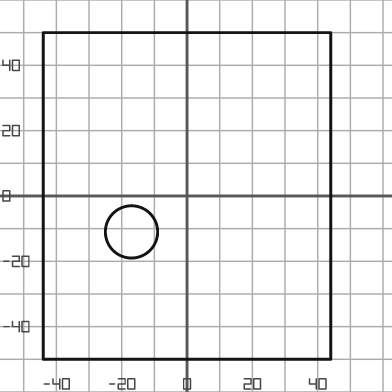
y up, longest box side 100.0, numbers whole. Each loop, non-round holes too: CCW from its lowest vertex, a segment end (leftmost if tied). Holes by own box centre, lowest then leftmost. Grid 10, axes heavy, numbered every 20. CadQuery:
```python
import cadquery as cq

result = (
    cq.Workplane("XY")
    .moveTo(-44.0, -50.0)
    .lineTo(44.0, -50.0)
    .lineTo(44.0, 50.0)
    .lineTo(-44.0, 50.0)
    .close()
    .moveTo(-17.0, -11.0)
    .circle(8.0)
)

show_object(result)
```